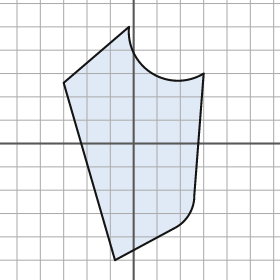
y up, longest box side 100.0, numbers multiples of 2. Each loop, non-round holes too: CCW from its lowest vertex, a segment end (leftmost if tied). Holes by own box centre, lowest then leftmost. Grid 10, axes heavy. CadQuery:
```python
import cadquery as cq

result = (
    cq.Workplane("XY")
    .moveTo(-8.0, -50.0)
    .lineTo(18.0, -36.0)
    .threePointArc((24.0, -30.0), (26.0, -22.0))
    .lineTo(30.0, 30.0)
    .threePointArc((8.0, 30.0), (-2.0, 50.0))
    .lineTo(-30.0, 26.0)
    .close()
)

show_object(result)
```